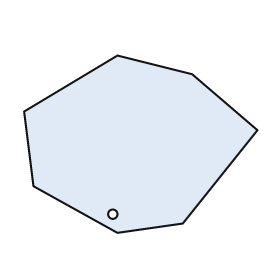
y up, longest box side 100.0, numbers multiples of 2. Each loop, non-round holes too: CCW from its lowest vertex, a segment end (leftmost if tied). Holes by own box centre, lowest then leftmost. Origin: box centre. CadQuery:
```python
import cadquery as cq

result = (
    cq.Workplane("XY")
    .moveTo(-10.0, -38.0)
    .lineTo(18.0, -34.0)
    .lineTo(50.0, 6.0)
    .lineTo(22.0, 30.0)
    .lineTo(-10.0, 38.0)
    .lineTo(-50.0, 14.0)
    .lineTo(-46.0, -18.0)
    .close()
    .moveTo(-12.0, -30.0)
    .circle(2.0)
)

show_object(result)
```